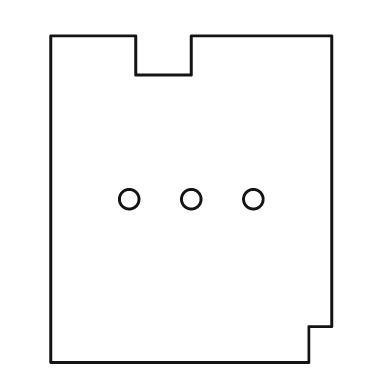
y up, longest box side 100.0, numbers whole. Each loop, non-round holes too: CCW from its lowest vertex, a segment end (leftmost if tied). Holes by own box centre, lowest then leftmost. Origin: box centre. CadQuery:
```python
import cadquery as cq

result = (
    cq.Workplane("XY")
    .moveTo(-43.0, -50.0)
    .lineTo(36.0, -50.0)
    .lineTo(36.0, -39.0)
    .lineTo(43.0, -39.0)
    .lineTo(43.0, 50.0)
    .lineTo(0.0, 50.0)
    .lineTo(0.0, 38.0)
    .lineTo(-17.0, 38.0)
    .lineTo(-17.0, 50.0)
    .lineTo(-43.0, 50.0)
    .close()
    .moveTo(-19.0, 0.0)
    .circle(3.0)
    .moveTo(0.0, 0.0)
    .circle(3.0)
    .moveTo(19.0, 0.0)
    .circle(3.0)
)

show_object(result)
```